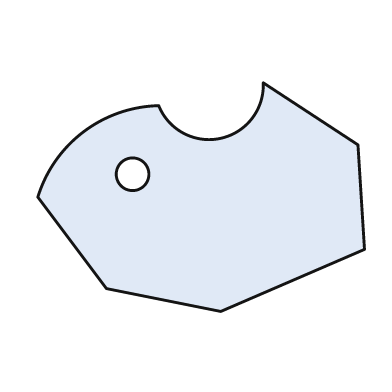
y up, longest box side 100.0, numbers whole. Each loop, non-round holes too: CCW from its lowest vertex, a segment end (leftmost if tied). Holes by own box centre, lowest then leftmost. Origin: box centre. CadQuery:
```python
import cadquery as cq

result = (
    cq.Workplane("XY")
    .moveTo(6.0, -35.0)
    .lineTo(50.0, -16.0)
    .lineTo(48.0, 16.0)
    .lineTo(19.0, 35.0)
    .threePointArc((6.0, 18.0), (-13.0, 28.0))
    .threePointArc((-36.0, 20.0), (-50.0, 0.0))
    .lineTo(-29.0, -28.0)
    .close()
    .moveTo(-21.0, 7.0)
    .circle(5.0)
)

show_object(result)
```